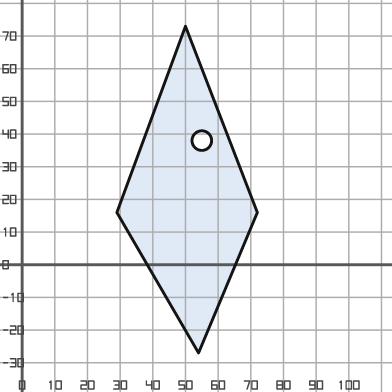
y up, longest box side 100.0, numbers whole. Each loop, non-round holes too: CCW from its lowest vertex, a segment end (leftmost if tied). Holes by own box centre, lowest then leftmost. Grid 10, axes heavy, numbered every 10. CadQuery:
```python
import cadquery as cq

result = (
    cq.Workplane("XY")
    .moveTo(54.0, -27.0)
    .lineTo(72.0, 16.0)
    .lineTo(50.0, 73.0)
    .lineTo(29.0, 16.0)
    .close()
    .moveTo(55.0, 38.0)
    .circle(3.0)
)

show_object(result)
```